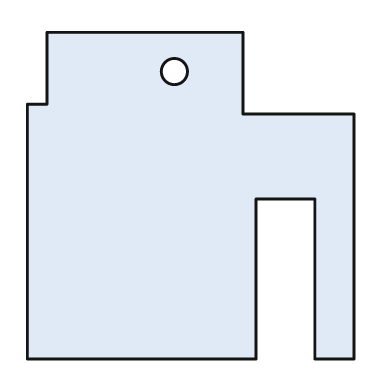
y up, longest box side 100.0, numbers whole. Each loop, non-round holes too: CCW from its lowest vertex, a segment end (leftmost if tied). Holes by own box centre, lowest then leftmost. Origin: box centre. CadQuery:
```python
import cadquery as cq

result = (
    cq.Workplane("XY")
    .moveTo(-50.0, -50.0)
    .lineTo(20.0, -50.0)
    .lineTo(20.0, -1.0)
    .lineTo(38.0, -1.0)
    .lineTo(38.0, -50.0)
    .lineTo(50.0, -50.0)
    .lineTo(50.0, 25.0)
    .lineTo(16.0, 25.0)
    .lineTo(16.0, 50.0)
    .lineTo(-44.0, 50.0)
    .lineTo(-44.0, 28.0)
    .lineTo(-50.0, 28.0)
    .close()
    .moveTo(-5.0, 38.0)
    .circle(4.0)
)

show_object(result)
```